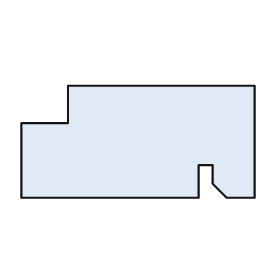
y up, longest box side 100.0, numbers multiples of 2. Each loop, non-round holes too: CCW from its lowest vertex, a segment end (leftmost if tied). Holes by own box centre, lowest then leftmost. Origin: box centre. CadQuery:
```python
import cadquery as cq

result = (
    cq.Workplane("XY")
    .moveTo(-50.0, -24.0)
    .lineTo(26.0, -24.0)
    .lineTo(26.0, -10.0)
    .lineTo(32.0, -10.0)
    .lineTo(32.0, -18.0)
    .lineTo(38.0, -24.0)
    .lineTo(50.0, -24.0)
    .lineTo(50.0, 24.0)
    .lineTo(-30.0, 24.0)
    .lineTo(-30.0, 8.0)
    .lineTo(-50.0, 8.0)
    .close()
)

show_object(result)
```